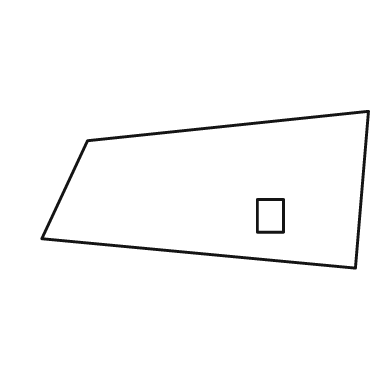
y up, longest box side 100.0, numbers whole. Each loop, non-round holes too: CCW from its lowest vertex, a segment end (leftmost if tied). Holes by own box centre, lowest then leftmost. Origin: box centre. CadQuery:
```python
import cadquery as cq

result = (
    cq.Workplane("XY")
    .moveTo(46.0, -24.0)
    .lineTo(50.0, 24.0)
    .lineTo(-36.0, 15.0)
    .lineTo(-50.0, -15.0)
    .close()
    .moveTo(16.0, -13.0)
    .lineTo(24.0, -13.0)
    .lineTo(24.0, -3.0)
    .lineTo(16.0, -3.0)
    .close()
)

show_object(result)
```